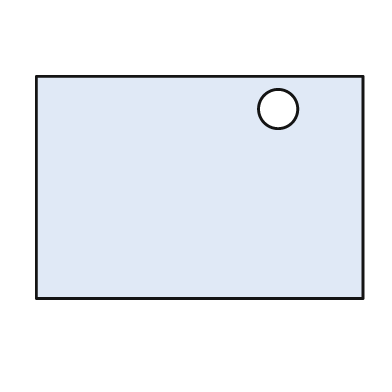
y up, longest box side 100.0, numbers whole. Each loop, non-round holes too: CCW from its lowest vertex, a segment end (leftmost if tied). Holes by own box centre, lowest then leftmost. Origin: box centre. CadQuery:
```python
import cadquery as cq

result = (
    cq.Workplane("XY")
    .moveTo(-50.0, -34.0)
    .lineTo(50.0, -34.0)
    .lineTo(50.0, 34.0)
    .lineTo(-50.0, 34.0)
    .close()
    .moveTo(24.0, 24.0)
    .circle(6.0)
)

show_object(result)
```